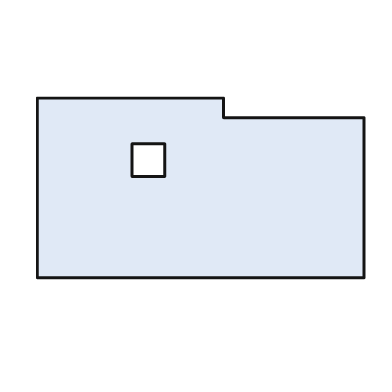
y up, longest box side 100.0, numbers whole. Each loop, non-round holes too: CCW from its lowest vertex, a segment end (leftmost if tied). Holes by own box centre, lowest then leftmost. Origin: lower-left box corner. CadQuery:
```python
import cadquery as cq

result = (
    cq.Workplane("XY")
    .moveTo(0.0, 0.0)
    .lineTo(100.0, 0.0)
    .lineTo(100.0, 49.0)
    .lineTo(57.0, 49.0)
    .lineTo(57.0, 55.0)
    .lineTo(0.0, 55.0)
    .close()
    .moveTo(29.0, 31.0)
    .lineTo(39.0, 31.0)
    .lineTo(39.0, 41.0)
    .lineTo(29.0, 41.0)
    .close()
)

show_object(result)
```